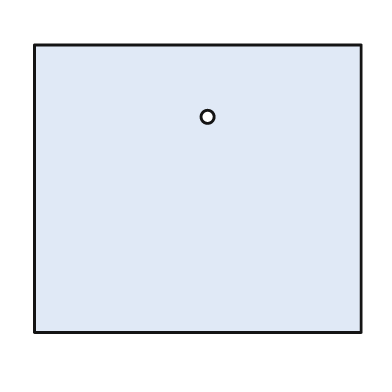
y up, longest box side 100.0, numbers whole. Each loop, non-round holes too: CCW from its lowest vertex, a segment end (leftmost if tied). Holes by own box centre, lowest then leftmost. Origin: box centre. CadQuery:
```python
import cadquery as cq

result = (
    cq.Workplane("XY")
    .moveTo(-50.0, -44.0)
    .lineTo(50.0, -44.0)
    .lineTo(50.0, 44.0)
    .lineTo(-50.0, 44.0)
    .close()
    .moveTo(3.0, 22.0)
    .circle(2.0)
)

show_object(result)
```